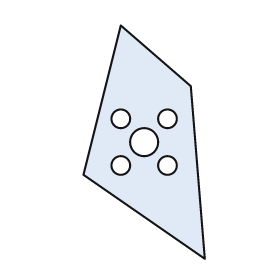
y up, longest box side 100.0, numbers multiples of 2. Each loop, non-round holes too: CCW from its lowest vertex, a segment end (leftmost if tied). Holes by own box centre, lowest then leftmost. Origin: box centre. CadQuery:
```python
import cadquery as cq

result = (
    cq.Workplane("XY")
    .moveTo(26.0, -50.0)
    .lineTo(20.0, 24.0)
    .lineTo(-10.0, 50.0)
    .lineTo(-26.0, -14.0)
    .close()
    .moveTo(-10.0, -10.0)
    .circle(4.0)
    .moveTo(10.0, -10.0)
    .circle(4.0)
    .moveTo(0.0, 0.0)
    .circle(6.0)
    .moveTo(-10.0, 10.0)
    .circle(4.0)
    .moveTo(10.0, 10.0)
    .circle(4.0)
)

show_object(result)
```